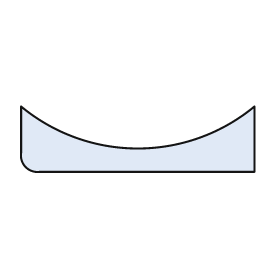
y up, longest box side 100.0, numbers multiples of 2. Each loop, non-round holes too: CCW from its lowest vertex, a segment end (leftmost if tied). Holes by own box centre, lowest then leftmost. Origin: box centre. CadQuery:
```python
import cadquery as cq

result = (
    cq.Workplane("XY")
    .moveTo(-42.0, -14.0)
    .lineTo(50.0, -14.0)
    .lineTo(50.0, 14.0)
    .threePointArc((0.0, -4.0), (-50.0, 14.0))
    .lineTo(-50.0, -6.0)
    .threePointArc((-48.0, -12.0), (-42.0, -14.0))
    .close()
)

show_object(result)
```